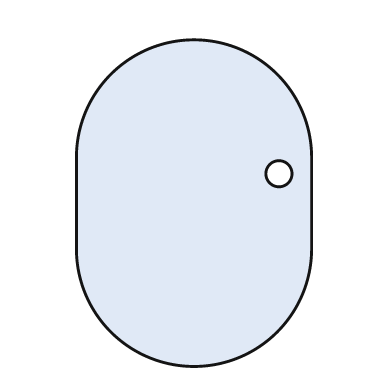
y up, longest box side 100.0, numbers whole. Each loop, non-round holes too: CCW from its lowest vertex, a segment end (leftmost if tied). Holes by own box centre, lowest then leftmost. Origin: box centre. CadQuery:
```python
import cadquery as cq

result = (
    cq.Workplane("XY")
    .moveTo(-36.0, -14.0)
    .threePointArc((0.0, -50.0), (36.0, -14.0))
    .lineTo(36.0, 14.0)
    .threePointArc((0.0, 50.0), (-36.0, 14.0))
    .close()
    .moveTo(26.0, 9.0)
    .circle(4.0)
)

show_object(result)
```